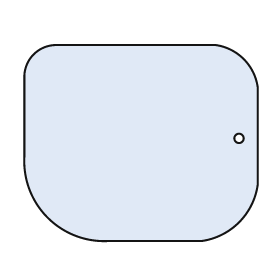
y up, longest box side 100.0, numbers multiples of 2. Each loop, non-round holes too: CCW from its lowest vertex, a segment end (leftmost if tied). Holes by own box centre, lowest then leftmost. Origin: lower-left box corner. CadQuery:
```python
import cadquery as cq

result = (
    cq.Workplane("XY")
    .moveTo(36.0, 0.0)
    .lineTo(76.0, 0.0)
    .threePointArc((92.0, 8.0), (100.0, 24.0))
    .lineTo(100.0, 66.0)
    .threePointArc((94.0, 78.0), (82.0, 84.0))
    .lineTo(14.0, 84.0)
    .threePointArc((4.0, 80.0), (0.0, 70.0))
    .lineTo(0.0, 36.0)
    .threePointArc((10.0, 10.0), (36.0, 0.0))
    .close()
    .moveTo(92.0, 44.0)
    .circle(2.0)
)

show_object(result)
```